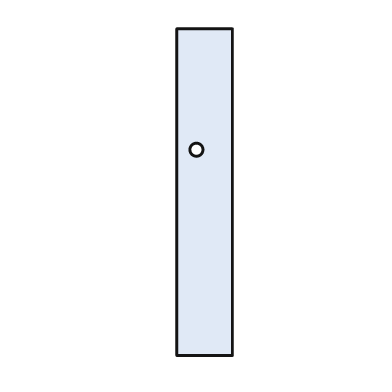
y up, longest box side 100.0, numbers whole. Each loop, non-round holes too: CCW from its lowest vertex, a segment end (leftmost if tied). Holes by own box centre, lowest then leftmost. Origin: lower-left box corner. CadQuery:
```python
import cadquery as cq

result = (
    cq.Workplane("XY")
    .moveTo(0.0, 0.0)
    .lineTo(17.0, 0.0)
    .lineTo(17.0, 100.0)
    .lineTo(0.0, 100.0)
    .close()
    .moveTo(6.0, 63.0)
    .circle(2.0)
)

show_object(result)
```